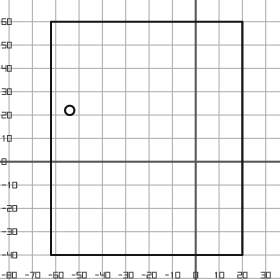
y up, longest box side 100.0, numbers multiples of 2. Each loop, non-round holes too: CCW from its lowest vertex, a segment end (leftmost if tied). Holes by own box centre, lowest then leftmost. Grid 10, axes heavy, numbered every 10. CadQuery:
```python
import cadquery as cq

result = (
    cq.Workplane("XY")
    .moveTo(-62.0, -40.0)
    .lineTo(20.0, -40.0)
    .lineTo(20.0, 60.0)
    .lineTo(-62.0, 60.0)
    .close()
    .moveTo(-54.0, 22.0)
    .circle(2.0)
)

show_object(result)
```